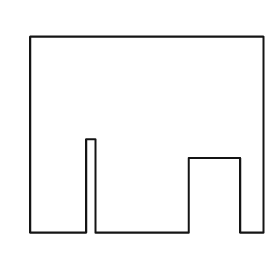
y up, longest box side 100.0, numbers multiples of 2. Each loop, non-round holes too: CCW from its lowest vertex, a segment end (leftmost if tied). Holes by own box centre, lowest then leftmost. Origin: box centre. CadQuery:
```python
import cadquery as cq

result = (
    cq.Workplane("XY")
    .moveTo(-50.0, -42.0)
    .lineTo(-26.0, -42.0)
    .lineTo(-26.0, -2.0)
    .lineTo(-22.0, -2.0)
    .lineTo(-22.0, -42.0)
    .lineTo(18.0, -42.0)
    .lineTo(18.0, -10.0)
    .lineTo(40.0, -10.0)
    .lineTo(40.0, -42.0)
    .lineTo(50.0, -42.0)
    .lineTo(50.0, 42.0)
    .lineTo(-50.0, 42.0)
    .close()
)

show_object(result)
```